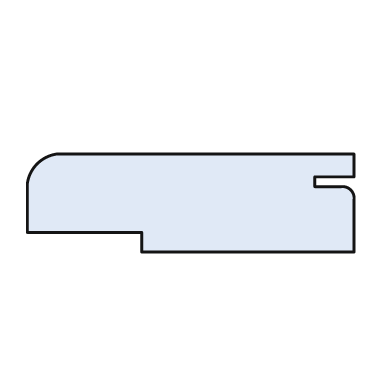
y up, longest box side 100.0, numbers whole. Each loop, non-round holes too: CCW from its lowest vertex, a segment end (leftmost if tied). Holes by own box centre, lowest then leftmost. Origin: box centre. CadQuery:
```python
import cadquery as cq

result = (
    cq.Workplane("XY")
    .moveTo(-15.0, -15.0)
    .lineTo(50.0, -15.0)
    .lineTo(50.0, 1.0)
    .threePointArc((49.0, 4.0), (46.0, 5.0))
    .lineTo(38.0, 5.0)
    .lineTo(38.0, 8.0)
    .lineTo(50.0, 8.0)
    .lineTo(50.0, 15.0)
    .lineTo(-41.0, 15.0)
    .threePointArc((-47.0, 12.0), (-50.0, 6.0))
    .lineTo(-50.0, -9.0)
    .lineTo(-15.0, -9.0)
    .close()
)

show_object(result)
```